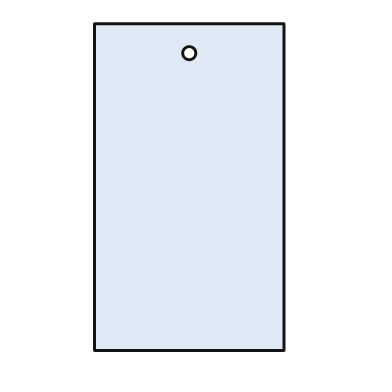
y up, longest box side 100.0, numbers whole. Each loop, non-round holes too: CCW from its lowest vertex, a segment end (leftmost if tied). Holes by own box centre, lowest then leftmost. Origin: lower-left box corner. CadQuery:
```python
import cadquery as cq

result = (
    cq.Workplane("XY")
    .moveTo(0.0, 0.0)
    .lineTo(58.0, 0.0)
    .lineTo(58.0, 100.0)
    .lineTo(0.0, 100.0)
    .close()
    .moveTo(29.0, 91.0)
    .circle(2.0)
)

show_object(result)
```